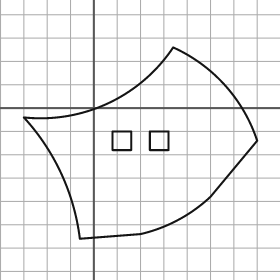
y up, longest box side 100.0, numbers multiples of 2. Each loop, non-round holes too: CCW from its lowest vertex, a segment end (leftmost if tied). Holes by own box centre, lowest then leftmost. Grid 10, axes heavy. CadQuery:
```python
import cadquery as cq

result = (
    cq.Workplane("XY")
    .moveTo(-6.0, -56.0)
    .lineTo(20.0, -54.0)
    .threePointArc((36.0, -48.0), (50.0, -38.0))
    .lineTo(70.0, -14.0)
    .threePointArc((56.0, 10.0), (34.0, 26.0))
    .threePointArc((6.0, 2.0), (-30.0, -4.0))
    .threePointArc((-14.0, -28.0), (-6.0, -56.0))
    .close()
    .moveTo(8.0, -18.0)
    .lineTo(16.0, -18.0)
    .lineTo(16.0, -10.0)
    .lineTo(8.0, -10.0)
    .close()
    .moveTo(24.0, -18.0)
    .lineTo(32.0, -18.0)
    .lineTo(32.0, -10.0)
    .lineTo(24.0, -10.0)
    .close()
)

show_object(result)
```